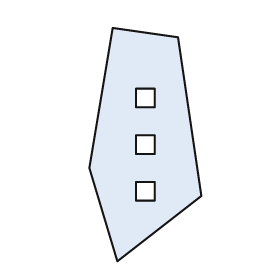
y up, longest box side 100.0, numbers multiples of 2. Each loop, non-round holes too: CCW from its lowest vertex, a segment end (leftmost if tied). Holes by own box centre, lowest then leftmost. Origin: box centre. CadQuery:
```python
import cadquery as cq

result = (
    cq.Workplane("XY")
    .moveTo(-12.0, -50.0)
    .lineTo(24.0, -22.0)
    .lineTo(14.0, 46.0)
    .lineTo(-14.0, 50.0)
    .lineTo(-24.0, -10.0)
    .close()
    .moveTo(-4.0, -24.0)
    .lineTo(4.0, -24.0)
    .lineTo(4.0, -16.0)
    .lineTo(-4.0, -16.0)
    .close()
    .moveTo(-4.0, -4.0)
    .lineTo(4.0, -4.0)
    .lineTo(4.0, 4.0)
    .lineTo(-4.0, 4.0)
    .close()
    .moveTo(-4.0, 16.0)
    .lineTo(4.0, 16.0)
    .lineTo(4.0, 24.0)
    .lineTo(-4.0, 24.0)
    .close()
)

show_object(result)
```